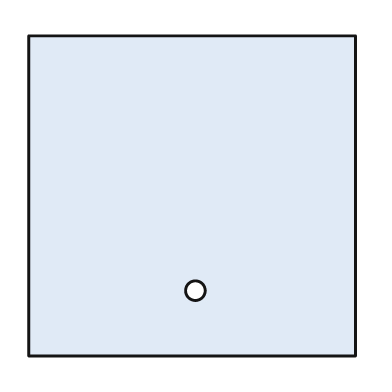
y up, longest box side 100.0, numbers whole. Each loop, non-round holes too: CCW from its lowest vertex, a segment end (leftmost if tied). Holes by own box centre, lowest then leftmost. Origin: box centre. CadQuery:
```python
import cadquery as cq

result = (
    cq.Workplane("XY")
    .moveTo(-50.0, -49.0)
    .lineTo(50.0, -49.0)
    .lineTo(50.0, 49.0)
    .lineTo(-50.0, 49.0)
    .close()
    .moveTo(1.0, -29.0)
    .circle(3.0)
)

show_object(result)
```